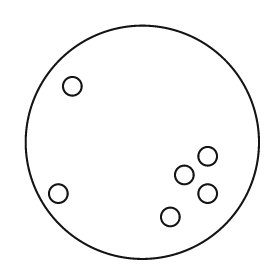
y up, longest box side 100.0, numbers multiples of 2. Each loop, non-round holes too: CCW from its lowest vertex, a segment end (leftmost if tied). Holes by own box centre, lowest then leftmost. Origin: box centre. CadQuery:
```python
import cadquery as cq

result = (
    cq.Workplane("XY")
    .moveTo(0.0, 0.0)
    .circle(50.0)
    .moveTo(12.0, -32.0)
    .circle(4.0)
    .moveTo(-36.0, -22.0)
    .circle(4.0)
    .moveTo(28.0, -22.0)
    .circle(4.0)
    .moveTo(18.0, -14.0)
    .circle(4.0)
    .moveTo(28.0, -6.0)
    .circle(4.0)
    .moveTo(-30.0, 24.0)
    .circle(4.0)
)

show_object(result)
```